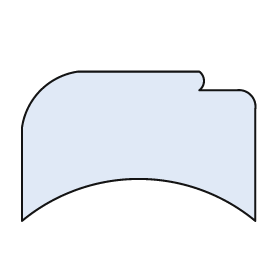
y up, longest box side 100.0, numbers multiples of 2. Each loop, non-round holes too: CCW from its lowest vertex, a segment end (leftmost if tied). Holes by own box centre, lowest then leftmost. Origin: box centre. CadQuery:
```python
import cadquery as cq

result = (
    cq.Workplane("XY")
    .moveTo(-50.0, -32.0)
    .threePointArc((0.0, -14.0), (50.0, -32.0))
    .lineTo(50.0, 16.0)
    .threePointArc((48.0, 22.0), (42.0, 24.0))
    .lineTo(26.0, 24.0)
    .threePointArc((28.0, 28.0), (26.0, 32.0))
    .lineTo(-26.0, 32.0)
    .threePointArc((-42.0, 24.0), (-50.0, 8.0))
    .close()
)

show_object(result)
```